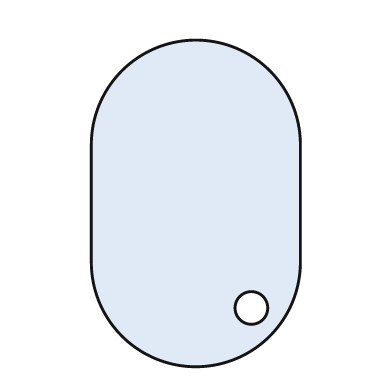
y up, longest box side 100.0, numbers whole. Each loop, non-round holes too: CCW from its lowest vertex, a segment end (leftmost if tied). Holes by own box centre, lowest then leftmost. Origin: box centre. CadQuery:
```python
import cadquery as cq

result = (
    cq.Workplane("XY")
    .moveTo(-32.0, -18.0)
    .threePointArc((0.0, -50.0), (32.0, -18.0))
    .lineTo(32.0, 18.0)
    .threePointArc((0.0, 50.0), (-32.0, 18.0))
    .close()
    .moveTo(17.0, -32.0)
    .circle(5.0)
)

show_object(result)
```